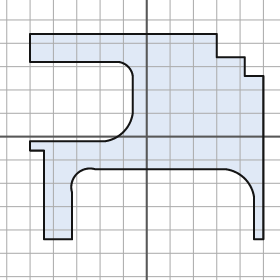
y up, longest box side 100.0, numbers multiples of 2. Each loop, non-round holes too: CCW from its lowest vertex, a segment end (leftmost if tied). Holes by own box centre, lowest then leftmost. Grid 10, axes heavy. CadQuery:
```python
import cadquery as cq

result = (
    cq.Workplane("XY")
    .moveTo(-44.0, -44.0)
    .lineTo(-32.0, -44.0)
    .lineTo(-32.0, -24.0)
    .threePointArc((-30.0, -16.0), (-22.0, -14.0))
    .lineTo(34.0, -14.0)
    .threePointArc((42.0, -18.0), (46.0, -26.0))
    .lineTo(46.0, -44.0)
    .lineTo(50.0, -44.0)
    .lineTo(50.0, 26.0)
    .lineTo(42.0, 26.0)
    .lineTo(42.0, 34.0)
    .lineTo(30.0, 34.0)
    .lineTo(30.0, 44.0)
    .lineTo(-50.0, 44.0)
    .lineTo(-50.0, 32.0)
    .lineTo(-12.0, 32.0)
    .threePointArc((-8.0, 30.0), (-6.0, 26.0))
    .lineTo(-6.0, 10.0)
    .threePointArc((-10.0, 2.0), (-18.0, -2.0))
    .lineTo(-50.0, -2.0)
    .lineTo(-50.0, -6.0)
    .lineTo(-44.0, -6.0)
    .close()
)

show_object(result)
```